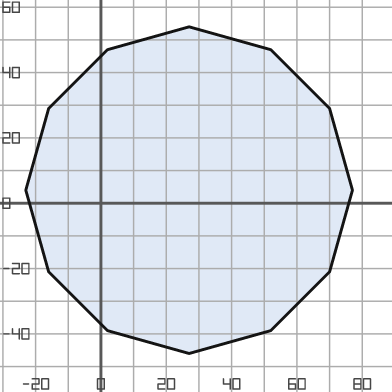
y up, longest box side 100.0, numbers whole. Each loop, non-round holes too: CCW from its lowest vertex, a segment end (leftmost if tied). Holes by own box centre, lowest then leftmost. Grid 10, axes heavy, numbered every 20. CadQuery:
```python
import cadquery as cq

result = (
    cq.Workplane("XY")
    .moveTo(27.0, -46.0)
    .lineTo(52.0, -39.0)
    .lineTo(70.0, -21.0)
    .lineTo(77.0, 4.0)
    .lineTo(70.0, 29.0)
    .lineTo(52.0, 47.0)
    .lineTo(27.0, 54.0)
    .lineTo(2.0, 47.0)
    .lineTo(-16.0, 29.0)
    .lineTo(-23.0, 4.0)
    .lineTo(-16.0, -21.0)
    .lineTo(2.0, -39.0)
    .close()
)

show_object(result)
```